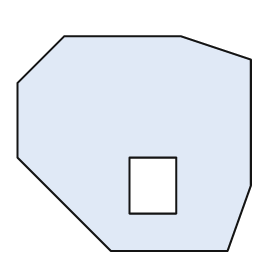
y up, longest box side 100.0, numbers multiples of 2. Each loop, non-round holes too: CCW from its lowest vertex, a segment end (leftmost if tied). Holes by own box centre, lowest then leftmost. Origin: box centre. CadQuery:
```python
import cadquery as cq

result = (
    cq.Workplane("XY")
    .moveTo(-10.0, -46.0)
    .lineTo(40.0, -46.0)
    .lineTo(50.0, -18.0)
    .lineTo(50.0, 36.0)
    .lineTo(20.0, 46.0)
    .lineTo(-30.0, 46.0)
    .lineTo(-50.0, 26.0)
    .lineTo(-50.0, -6.0)
    .close()
    .moveTo(-2.0, -30.0)
    .lineTo(18.0, -30.0)
    .lineTo(18.0, -6.0)
    .lineTo(-2.0, -6.0)
    .close()
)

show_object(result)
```